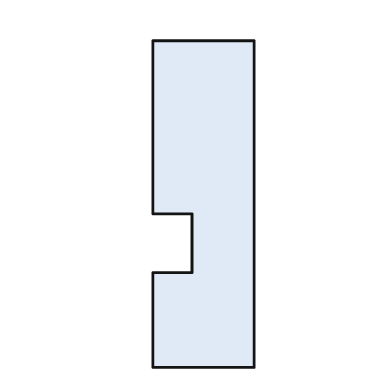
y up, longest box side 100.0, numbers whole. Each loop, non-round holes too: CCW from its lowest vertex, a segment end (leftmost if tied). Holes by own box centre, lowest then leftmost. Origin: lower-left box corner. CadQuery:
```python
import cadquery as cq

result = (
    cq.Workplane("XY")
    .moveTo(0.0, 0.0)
    .lineTo(31.0, 0.0)
    .lineTo(31.0, 100.0)
    .lineTo(0.0, 100.0)
    .lineTo(0.0, 47.0)
    .lineTo(12.0, 47.0)
    .lineTo(12.0, 29.0)
    .lineTo(0.0, 29.0)
    .close()
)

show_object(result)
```